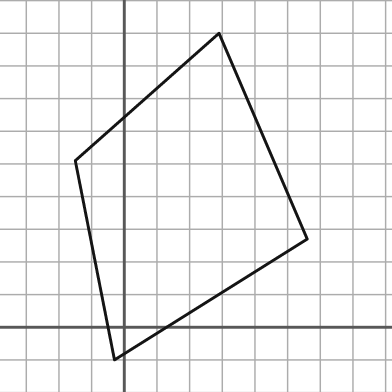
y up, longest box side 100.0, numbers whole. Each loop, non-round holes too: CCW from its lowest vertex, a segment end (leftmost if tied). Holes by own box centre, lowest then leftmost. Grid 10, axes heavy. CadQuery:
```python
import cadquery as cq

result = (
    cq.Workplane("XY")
    .moveTo(-3.0, -10.0)
    .lineTo(56.0, 27.0)
    .lineTo(29.0, 90.0)
    .lineTo(-15.0, 51.0)
    .close()
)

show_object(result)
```